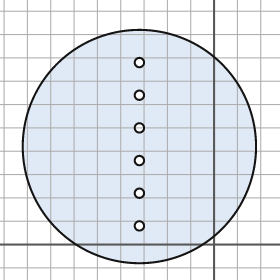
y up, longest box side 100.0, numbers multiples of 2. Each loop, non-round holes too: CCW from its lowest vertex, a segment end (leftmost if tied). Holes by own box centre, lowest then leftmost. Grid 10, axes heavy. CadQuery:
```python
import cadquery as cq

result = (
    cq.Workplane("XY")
    .moveTo(-32.0, 42.0)
    .circle(50.0)
    .moveTo(-32.0, 8.0)
    .circle(2.0)
    .moveTo(-32.0, 22.0)
    .circle(2.0)
    .moveTo(-32.0, 36.0)
    .circle(2.0)
    .moveTo(-32.0, 50.0)
    .circle(2.0)
    .moveTo(-32.0, 64.0)
    .circle(2.0)
    .moveTo(-32.0, 78.0)
    .circle(2.0)
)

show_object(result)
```